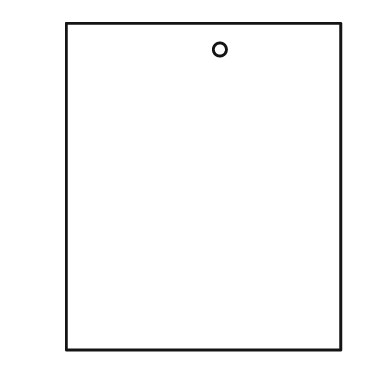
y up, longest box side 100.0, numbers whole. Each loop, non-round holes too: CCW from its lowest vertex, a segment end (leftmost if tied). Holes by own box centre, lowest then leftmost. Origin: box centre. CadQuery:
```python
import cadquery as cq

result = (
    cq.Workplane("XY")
    .moveTo(-42.0, -50.0)
    .lineTo(42.0, -50.0)
    .lineTo(42.0, 50.0)
    .lineTo(-42.0, 50.0)
    .close()
    .moveTo(5.0, 42.0)
    .circle(2.0)
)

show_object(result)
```